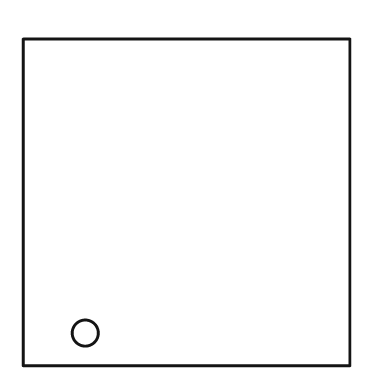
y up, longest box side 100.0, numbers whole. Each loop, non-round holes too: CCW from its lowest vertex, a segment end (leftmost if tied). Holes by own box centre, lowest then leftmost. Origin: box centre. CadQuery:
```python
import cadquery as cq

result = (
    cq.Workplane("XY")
    .moveTo(-50.0, -50.0)
    .lineTo(50.0, -50.0)
    .lineTo(50.0, 50.0)
    .lineTo(-50.0, 50.0)
    .close()
    .moveTo(-31.0, -40.0)
    .circle(4.0)
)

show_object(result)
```